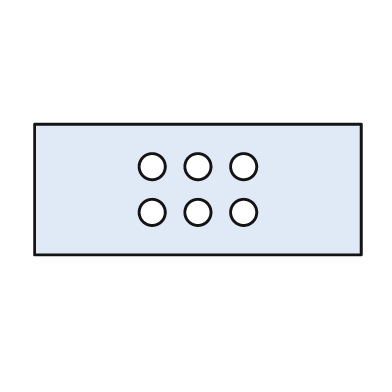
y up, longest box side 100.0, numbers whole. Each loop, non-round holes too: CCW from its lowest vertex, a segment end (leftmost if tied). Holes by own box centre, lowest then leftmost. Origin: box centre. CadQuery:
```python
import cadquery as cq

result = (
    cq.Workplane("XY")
    .moveTo(-50.0, -20.0)
    .lineTo(50.0, -20.0)
    .lineTo(50.0, 20.0)
    .lineTo(-50.0, 20.0)
    .close()
    .moveTo(-14.0, -7.0)
    .circle(4.0)
    .moveTo(0.0, -7.0)
    .circle(4.0)
    .moveTo(14.0, -7.0)
    .circle(4.0)
    .moveTo(-14.0, 7.0)
    .circle(4.0)
    .moveTo(0.0, 7.0)
    .circle(4.0)
    .moveTo(14.0, 7.0)
    .circle(4.0)
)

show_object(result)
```